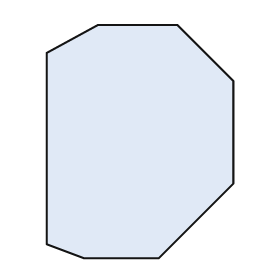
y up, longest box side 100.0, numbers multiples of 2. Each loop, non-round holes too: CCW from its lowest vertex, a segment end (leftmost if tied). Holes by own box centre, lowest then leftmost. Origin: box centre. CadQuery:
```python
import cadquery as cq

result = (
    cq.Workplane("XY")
    .moveTo(-24.0, -50.0)
    .lineTo(8.0, -50.0)
    .lineTo(40.0, -18.0)
    .lineTo(40.0, 26.0)
    .lineTo(16.0, 50.0)
    .lineTo(-18.0, 50.0)
    .lineTo(-40.0, 38.0)
    .lineTo(-40.0, -44.0)
    .close()
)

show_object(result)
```